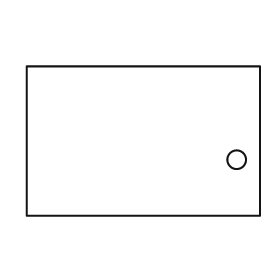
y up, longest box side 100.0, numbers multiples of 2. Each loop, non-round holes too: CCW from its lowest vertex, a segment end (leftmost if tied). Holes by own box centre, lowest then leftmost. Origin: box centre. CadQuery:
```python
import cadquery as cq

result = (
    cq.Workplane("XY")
    .moveTo(-50.0, -32.0)
    .lineTo(50.0, -32.0)
    .lineTo(50.0, 32.0)
    .lineTo(-50.0, 32.0)
    .close()
    .moveTo(40.0, -8.0)
    .circle(4.0)
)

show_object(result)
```